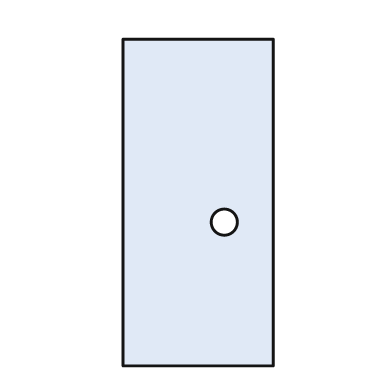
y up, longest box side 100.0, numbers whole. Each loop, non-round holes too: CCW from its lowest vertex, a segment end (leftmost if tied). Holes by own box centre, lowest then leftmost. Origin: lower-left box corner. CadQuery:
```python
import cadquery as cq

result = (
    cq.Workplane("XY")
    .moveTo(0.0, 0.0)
    .lineTo(46.0, 0.0)
    .lineTo(46.0, 100.0)
    .lineTo(0.0, 100.0)
    .close()
    .moveTo(31.0, 44.0)
    .circle(4.0)
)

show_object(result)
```